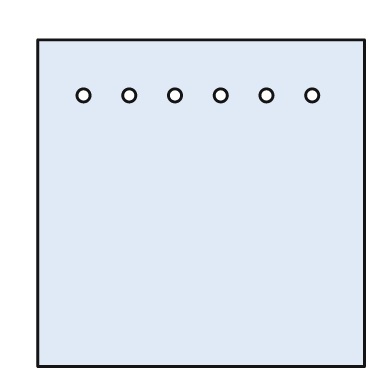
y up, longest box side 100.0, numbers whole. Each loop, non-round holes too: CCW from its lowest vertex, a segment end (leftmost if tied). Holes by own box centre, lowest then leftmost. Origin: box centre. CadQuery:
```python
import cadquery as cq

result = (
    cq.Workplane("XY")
    .moveTo(-50.0, -50.0)
    .lineTo(50.0, -50.0)
    .lineTo(50.0, 50.0)
    .lineTo(-50.0, 50.0)
    .close()
    .moveTo(-36.0, 33.0)
    .circle(2.0)
    .moveTo(-22.0, 33.0)
    .circle(2.0)
    .moveTo(-8.0, 33.0)
    .circle(2.0)
    .moveTo(6.0, 33.0)
    .circle(2.0)
    .moveTo(20.0, 33.0)
    .circle(2.0)
    .moveTo(34.0, 33.0)
    .circle(2.0)
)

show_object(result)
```